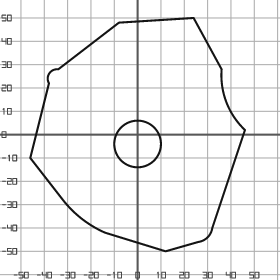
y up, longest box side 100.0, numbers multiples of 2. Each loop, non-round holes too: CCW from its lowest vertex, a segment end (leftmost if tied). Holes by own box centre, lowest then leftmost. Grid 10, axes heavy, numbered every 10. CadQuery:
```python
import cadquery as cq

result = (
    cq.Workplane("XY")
    .moveTo(12.0, -50.0)
    .lineTo(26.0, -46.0)
    .threePointArc((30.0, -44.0), (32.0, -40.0))
    .lineTo(46.0, 2.0)
    .threePointArc((38.0, 14.0), (36.0, 28.0))
    .lineTo(24.0, 50.0)
    .lineTo(-8.0, 48.0)
    .lineTo(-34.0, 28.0)
    .threePointArc((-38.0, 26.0), (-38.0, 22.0))
    .lineTo(-46.0, -10.0)
    .lineTo(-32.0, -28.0)
    .threePointArc((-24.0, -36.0), (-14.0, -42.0))
    .close()
    .moveTo(0.0, -4.0)
    .circle(10.0)
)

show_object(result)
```